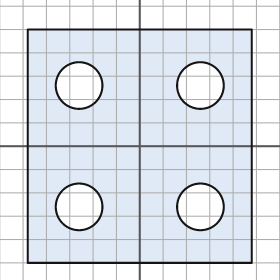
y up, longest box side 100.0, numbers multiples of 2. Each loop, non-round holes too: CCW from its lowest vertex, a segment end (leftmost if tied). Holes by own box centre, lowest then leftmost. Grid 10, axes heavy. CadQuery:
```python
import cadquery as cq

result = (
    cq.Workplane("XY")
    .moveTo(-48.0, -50.0)
    .lineTo(48.0, -50.0)
    .lineTo(48.0, 50.0)
    .lineTo(-48.0, 50.0)
    .close()
    .moveTo(-26.0, -26.0)
    .circle(10.0)
    .moveTo(26.0, -26.0)
    .circle(10.0)
    .moveTo(-26.0, 26.0)
    .circle(10.0)
    .moveTo(26.0, 26.0)
    .circle(10.0)
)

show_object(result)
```